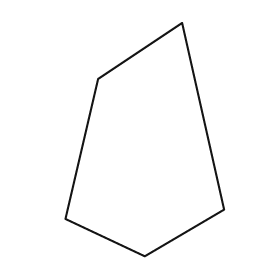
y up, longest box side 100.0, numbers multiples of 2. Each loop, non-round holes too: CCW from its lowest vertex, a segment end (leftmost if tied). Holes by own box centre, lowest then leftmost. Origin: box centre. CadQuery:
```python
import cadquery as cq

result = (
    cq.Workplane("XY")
    .moveTo(0.0, -50.0)
    .lineTo(34.0, -30.0)
    .lineTo(16.0, 50.0)
    .lineTo(-20.0, 26.0)
    .lineTo(-34.0, -34.0)
    .close()
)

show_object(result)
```